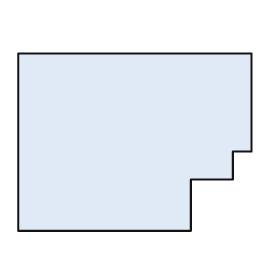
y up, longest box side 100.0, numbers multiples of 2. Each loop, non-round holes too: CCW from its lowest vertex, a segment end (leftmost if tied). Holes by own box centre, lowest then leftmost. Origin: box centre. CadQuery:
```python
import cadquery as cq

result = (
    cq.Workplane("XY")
    .moveTo(-50.0, -38.0)
    .lineTo(24.0, -38.0)
    .lineTo(24.0, -16.0)
    .lineTo(42.0, -16.0)
    .lineTo(42.0, -4.0)
    .lineTo(50.0, -4.0)
    .lineTo(50.0, 38.0)
    .lineTo(-50.0, 38.0)
    .close()
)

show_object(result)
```